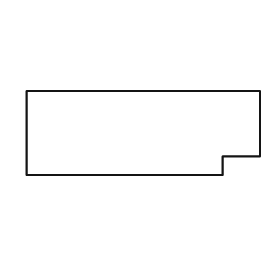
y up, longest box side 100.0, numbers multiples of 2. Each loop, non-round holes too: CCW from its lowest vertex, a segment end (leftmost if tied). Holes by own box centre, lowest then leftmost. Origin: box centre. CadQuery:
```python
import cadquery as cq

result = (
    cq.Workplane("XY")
    .moveTo(-50.0, -18.0)
    .lineTo(34.0, -18.0)
    .lineTo(34.0, -10.0)
    .lineTo(50.0, -10.0)
    .lineTo(50.0, 18.0)
    .lineTo(-50.0, 18.0)
    .close()
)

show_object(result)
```